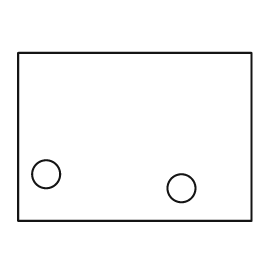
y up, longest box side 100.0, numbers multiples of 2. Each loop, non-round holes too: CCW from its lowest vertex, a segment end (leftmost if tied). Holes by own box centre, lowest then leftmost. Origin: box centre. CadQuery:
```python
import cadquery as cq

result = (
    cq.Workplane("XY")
    .moveTo(-50.0, -36.0)
    .lineTo(50.0, -36.0)
    .lineTo(50.0, 36.0)
    .lineTo(-50.0, 36.0)
    .close()
    .moveTo(20.0, -22.0)
    .circle(6.0)
    .moveTo(-38.0, -16.0)
    .circle(6.0)
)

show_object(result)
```